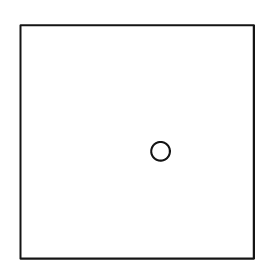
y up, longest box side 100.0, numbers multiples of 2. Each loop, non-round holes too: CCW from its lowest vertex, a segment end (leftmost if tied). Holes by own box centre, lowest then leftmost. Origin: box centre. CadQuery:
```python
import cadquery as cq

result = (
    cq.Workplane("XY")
    .moveTo(-50.0, -50.0)
    .lineTo(50.0, -50.0)
    .lineTo(50.0, 50.0)
    .lineTo(-50.0, 50.0)
    .close()
    .moveTo(10.0, -4.0)
    .circle(4.0)
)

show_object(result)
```